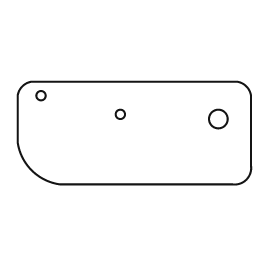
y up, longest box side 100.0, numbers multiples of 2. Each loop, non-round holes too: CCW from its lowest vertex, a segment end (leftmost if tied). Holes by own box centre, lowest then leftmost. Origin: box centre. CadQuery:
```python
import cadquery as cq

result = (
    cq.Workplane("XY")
    .moveTo(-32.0, -22.0)
    .lineTo(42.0, -22.0)
    .threePointArc((48.0, -20.0), (50.0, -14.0))
    .lineTo(50.0, 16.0)
    .threePointArc((48.0, 20.0), (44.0, 22.0))
    .lineTo(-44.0, 22.0)
    .threePointArc((-48.0, 20.0), (-50.0, 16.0))
    .lineTo(-50.0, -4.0)
    .threePointArc((-44.0, -16.0), (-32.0, -22.0))
    .close()
    .moveTo(36.0, 6.0)
    .circle(4.0)
    .moveTo(-6.0, 8.0)
    .circle(2.0)
    .moveTo(-40.0, 16.0)
    .circle(2.0)
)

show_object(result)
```